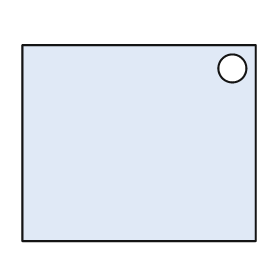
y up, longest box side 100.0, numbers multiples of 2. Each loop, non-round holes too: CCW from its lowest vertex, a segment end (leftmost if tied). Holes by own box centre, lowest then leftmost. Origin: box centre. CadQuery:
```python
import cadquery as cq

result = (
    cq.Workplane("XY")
    .moveTo(-50.0, -42.0)
    .lineTo(50.0, -42.0)
    .lineTo(50.0, 42.0)
    .lineTo(-50.0, 42.0)
    .close()
    .moveTo(40.0, 32.0)
    .circle(6.0)
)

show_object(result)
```